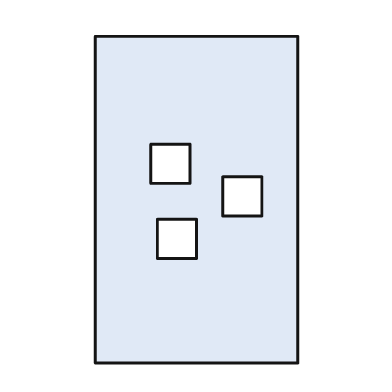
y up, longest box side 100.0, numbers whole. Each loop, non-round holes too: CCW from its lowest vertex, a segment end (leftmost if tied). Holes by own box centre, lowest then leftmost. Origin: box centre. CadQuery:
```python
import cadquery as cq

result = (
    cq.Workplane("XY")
    .moveTo(-31.0, -50.0)
    .lineTo(31.0, -50.0)
    .lineTo(31.0, 50.0)
    .lineTo(-31.0, 50.0)
    .close()
    .moveTo(-12.0, -18.0)
    .lineTo(0.0, -18.0)
    .lineTo(0.0, -6.0)
    .lineTo(-12.0, -6.0)
    .close()
    .moveTo(8.0, -5.0)
    .lineTo(20.0, -5.0)
    .lineTo(20.0, 7.0)
    .lineTo(8.0, 7.0)
    .close()
    .moveTo(-14.0, 5.0)
    .lineTo(-2.0, 5.0)
    .lineTo(-2.0, 17.0)
    .lineTo(-14.0, 17.0)
    .close()
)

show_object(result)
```